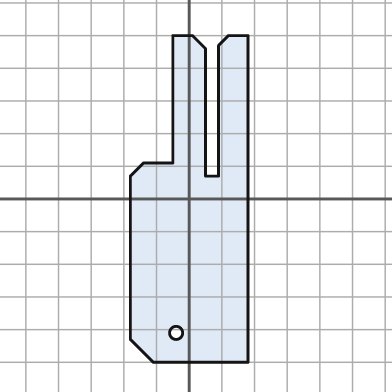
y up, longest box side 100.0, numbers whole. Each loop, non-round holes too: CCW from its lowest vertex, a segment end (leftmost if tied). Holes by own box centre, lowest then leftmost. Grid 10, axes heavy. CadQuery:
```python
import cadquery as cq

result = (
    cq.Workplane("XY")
    .moveTo(-11.0, -50.0)
    .lineTo(18.0, -50.0)
    .lineTo(18.0, 50.0)
    .lineTo(12.0, 50.0)
    .lineTo(9.0, 47.0)
    .lineTo(9.0, 7.0)
    .lineTo(5.0, 7.0)
    .lineTo(5.0, 46.0)
    .lineTo(1.0, 50.0)
    .lineTo(-5.0, 50.0)
    .lineTo(-5.0, 11.0)
    .lineTo(-14.0, 11.0)
    .lineTo(-18.0, 7.0)
    .lineTo(-18.0, -43.0)
    .close()
    .moveTo(-4.0, -41.0)
    .circle(2.0)
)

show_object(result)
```